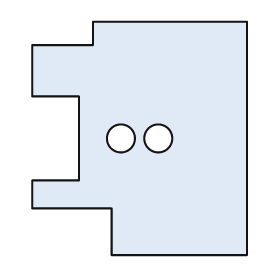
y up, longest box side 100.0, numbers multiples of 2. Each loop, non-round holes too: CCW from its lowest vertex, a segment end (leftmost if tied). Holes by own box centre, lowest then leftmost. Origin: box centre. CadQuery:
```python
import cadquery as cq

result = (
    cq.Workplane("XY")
    .moveTo(-12.0, -50.0)
    .lineTo(46.0, -50.0)
    .lineTo(46.0, 50.0)
    .lineTo(-20.0, 50.0)
    .lineTo(-20.0, 40.0)
    .lineTo(-46.0, 40.0)
    .lineTo(-46.0, 18.0)
    .lineTo(-26.0, 18.0)
    .lineTo(-26.0, -18.0)
    .lineTo(-46.0, -18.0)
    .lineTo(-46.0, -30.0)
    .lineTo(-12.0, -30.0)
    .close()
    .moveTo(-8.0, 0.0)
    .circle(6.0)
    .moveTo(8.0, 0.0)
    .circle(6.0)
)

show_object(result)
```